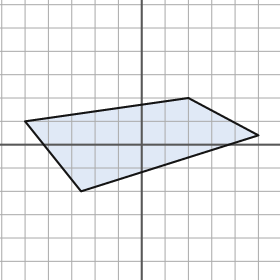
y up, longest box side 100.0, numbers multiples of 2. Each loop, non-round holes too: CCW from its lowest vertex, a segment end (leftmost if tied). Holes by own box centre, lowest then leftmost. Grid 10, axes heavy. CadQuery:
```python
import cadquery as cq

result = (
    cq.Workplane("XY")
    .moveTo(-26.0, -20.0)
    .lineTo(50.0, 4.0)
    .lineTo(20.0, 20.0)
    .lineTo(-50.0, 10.0)
    .close()
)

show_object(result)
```